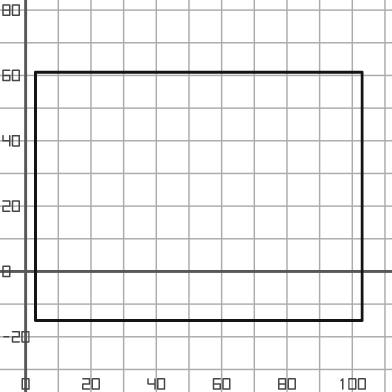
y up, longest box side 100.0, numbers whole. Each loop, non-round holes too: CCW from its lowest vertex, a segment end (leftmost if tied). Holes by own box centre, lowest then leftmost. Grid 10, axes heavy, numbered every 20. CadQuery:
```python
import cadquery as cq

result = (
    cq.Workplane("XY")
    .moveTo(3.0, -15.0)
    .lineTo(103.0, -15.0)
    .lineTo(103.0, 61.0)
    .lineTo(3.0, 61.0)
    .close()
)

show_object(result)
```